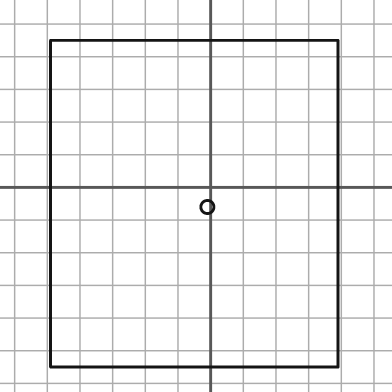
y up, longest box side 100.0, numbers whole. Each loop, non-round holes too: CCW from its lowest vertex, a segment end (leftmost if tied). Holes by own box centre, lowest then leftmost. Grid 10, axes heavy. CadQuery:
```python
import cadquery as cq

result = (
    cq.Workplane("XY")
    .moveTo(-49.0, -55.0)
    .lineTo(39.0, -55.0)
    .lineTo(39.0, 45.0)
    .lineTo(-49.0, 45.0)
    .close()
    .moveTo(-1.0, -6.0)
    .circle(2.0)
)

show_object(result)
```